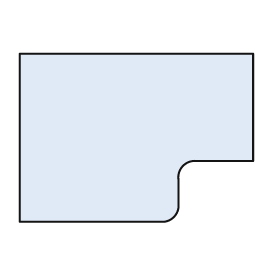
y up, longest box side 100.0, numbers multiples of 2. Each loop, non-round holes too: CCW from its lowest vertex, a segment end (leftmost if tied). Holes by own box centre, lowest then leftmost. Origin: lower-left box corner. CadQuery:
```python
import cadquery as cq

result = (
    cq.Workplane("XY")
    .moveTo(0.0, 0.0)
    .lineTo(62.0, 0.0)
    .threePointArc((66.0, 2.0), (68.0, 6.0))
    .lineTo(68.0, 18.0)
    .threePointArc((70.0, 24.0), (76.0, 26.0))
    .lineTo(100.0, 26.0)
    .lineTo(100.0, 72.0)
    .lineTo(0.0, 72.0)
    .close()
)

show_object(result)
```